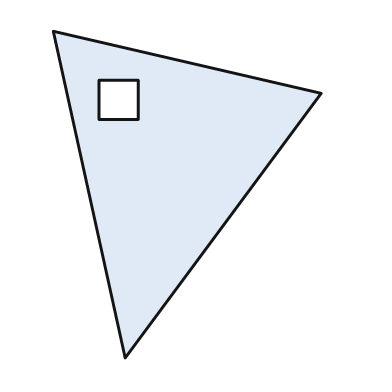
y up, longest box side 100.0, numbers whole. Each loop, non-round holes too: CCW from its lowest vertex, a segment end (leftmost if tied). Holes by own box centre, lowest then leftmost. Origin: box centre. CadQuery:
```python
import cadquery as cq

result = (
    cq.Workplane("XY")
    .moveTo(-19.0, -50.0)
    .lineTo(41.0, 31.0)
    .lineTo(-41.0, 50.0)
    .close()
    .moveTo(-27.0, 23.0)
    .lineTo(-15.0, 23.0)
    .lineTo(-15.0, 35.0)
    .lineTo(-27.0, 35.0)
    .close()
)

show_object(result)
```